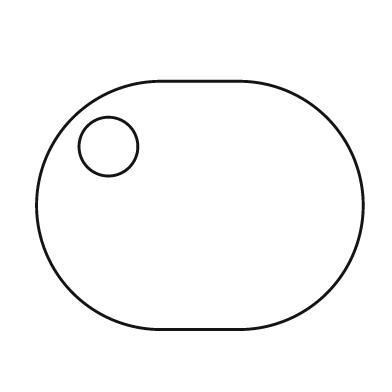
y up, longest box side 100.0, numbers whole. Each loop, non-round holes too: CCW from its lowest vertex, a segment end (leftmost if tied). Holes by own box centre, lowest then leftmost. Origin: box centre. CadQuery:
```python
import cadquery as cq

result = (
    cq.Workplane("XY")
    .moveTo(-12.0, -38.0)
    .lineTo(12.0, -38.0)
    .threePointArc((50.0, 0.0), (12.0, 38.0))
    .lineTo(-12.0, 38.0)
    .threePointArc((-50.0, 0.0), (-12.0, -38.0))
    .close()
    .moveTo(-28.0, 18.0)
    .circle(9.0)
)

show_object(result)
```